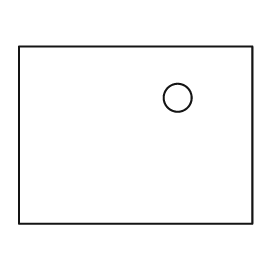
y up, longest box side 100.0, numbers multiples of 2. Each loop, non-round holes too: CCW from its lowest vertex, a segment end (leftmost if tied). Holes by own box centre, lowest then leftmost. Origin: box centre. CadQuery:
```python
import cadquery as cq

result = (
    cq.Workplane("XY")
    .moveTo(-50.0, -38.0)
    .lineTo(50.0, -38.0)
    .lineTo(50.0, 38.0)
    .lineTo(-50.0, 38.0)
    .close()
    .moveTo(18.0, 16.0)
    .circle(6.0)
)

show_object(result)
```